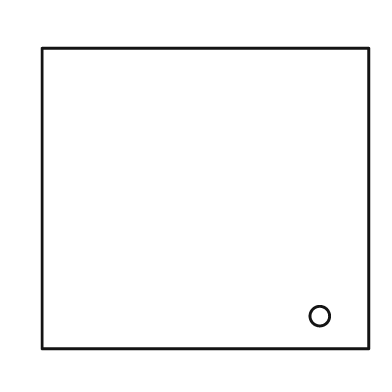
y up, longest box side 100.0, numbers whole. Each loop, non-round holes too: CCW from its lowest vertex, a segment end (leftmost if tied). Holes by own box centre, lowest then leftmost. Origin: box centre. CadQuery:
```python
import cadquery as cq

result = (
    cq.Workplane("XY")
    .moveTo(-50.0, -46.0)
    .lineTo(50.0, -46.0)
    .lineTo(50.0, 46.0)
    .lineTo(-50.0, 46.0)
    .close()
    .moveTo(35.0, -36.0)
    .circle(3.0)
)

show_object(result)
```